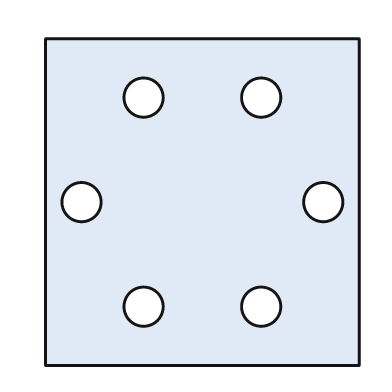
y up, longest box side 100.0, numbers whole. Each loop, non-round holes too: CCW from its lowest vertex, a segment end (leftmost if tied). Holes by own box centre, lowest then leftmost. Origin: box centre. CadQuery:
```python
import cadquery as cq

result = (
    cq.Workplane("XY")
    .moveTo(-48.0, -50.0)
    .lineTo(48.0, -50.0)
    .lineTo(48.0, 50.0)
    .lineTo(-48.0, 50.0)
    .close()
    .moveTo(-18.0, -32.0)
    .circle(6.0)
    .moveTo(18.0, -32.0)
    .circle(6.0)
    .moveTo(-37.0, 0.0)
    .circle(6.0)
    .moveTo(37.0, 0.0)
    .circle(6.0)
    .moveTo(-18.0, 32.0)
    .circle(6.0)
    .moveTo(18.0, 32.0)
    .circle(6.0)
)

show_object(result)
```